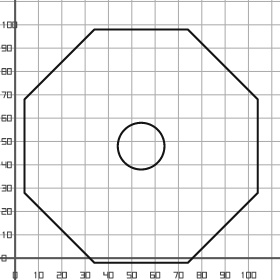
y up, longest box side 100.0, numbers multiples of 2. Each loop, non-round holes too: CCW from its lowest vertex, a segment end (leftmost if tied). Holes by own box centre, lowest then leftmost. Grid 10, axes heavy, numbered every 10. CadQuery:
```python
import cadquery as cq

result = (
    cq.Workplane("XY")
    .moveTo(34.0, -2.0)
    .lineTo(74.0, -2.0)
    .lineTo(104.0, 28.0)
    .lineTo(104.0, 68.0)
    .lineTo(74.0, 98.0)
    .lineTo(34.0, 98.0)
    .lineTo(4.0, 68.0)
    .lineTo(4.0, 28.0)
    .close()
    .moveTo(54.0, 48.0)
    .circle(10.0)
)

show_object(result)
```